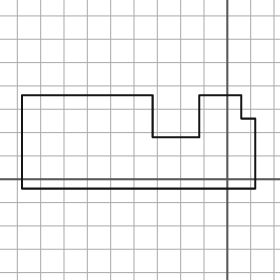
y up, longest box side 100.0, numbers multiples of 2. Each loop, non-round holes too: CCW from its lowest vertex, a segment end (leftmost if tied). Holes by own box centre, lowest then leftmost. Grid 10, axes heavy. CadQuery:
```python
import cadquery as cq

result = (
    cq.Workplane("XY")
    .moveTo(-88.0, -4.0)
    .lineTo(12.0, -4.0)
    .lineTo(12.0, 26.0)
    .lineTo(6.0, 26.0)
    .lineTo(6.0, 36.0)
    .lineTo(-12.0, 36.0)
    .lineTo(-12.0, 18.0)
    .lineTo(-32.0, 18.0)
    .lineTo(-32.0, 36.0)
    .lineTo(-88.0, 36.0)
    .close()
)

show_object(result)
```